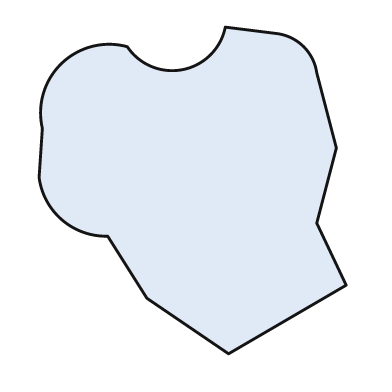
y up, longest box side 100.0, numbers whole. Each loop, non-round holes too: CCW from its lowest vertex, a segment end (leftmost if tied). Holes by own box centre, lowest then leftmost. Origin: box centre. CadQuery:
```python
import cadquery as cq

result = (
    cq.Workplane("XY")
    .moveTo(11.0, -50.0)
    .lineTo(47.0, -29.0)
    .lineTo(38.0, -10.0)
    .lineTo(44.0, 13.0)
    .lineTo(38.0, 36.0)
    .threePointArc((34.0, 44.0), (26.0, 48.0))
    .lineTo(10.0, 50.0)
    .threePointArc((-3.0, 37.0), (-20.0, 44.0))
    .threePointArc((-40.0, 39.0), (-46.0, 19.0))
    .lineTo(-47.0, 4.0)
    .threePointArc((-40.0, -9.0), (-26.0, -14.0))
    .lineTo(-14.0, -33.0)
    .close()
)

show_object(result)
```